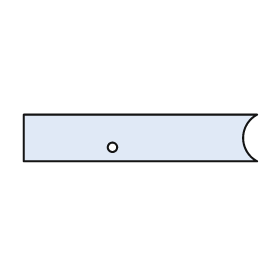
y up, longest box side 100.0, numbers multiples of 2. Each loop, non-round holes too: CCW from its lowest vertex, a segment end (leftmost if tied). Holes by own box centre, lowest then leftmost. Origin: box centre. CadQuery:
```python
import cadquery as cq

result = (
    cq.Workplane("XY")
    .moveTo(-50.0, -10.0)
    .lineTo(50.0, -10.0)
    .threePointArc((44.0, 0.0), (50.0, 10.0))
    .lineTo(-50.0, 10.0)
    .close()
    .moveTo(-12.0, -4.0)
    .circle(2.0)
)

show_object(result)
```